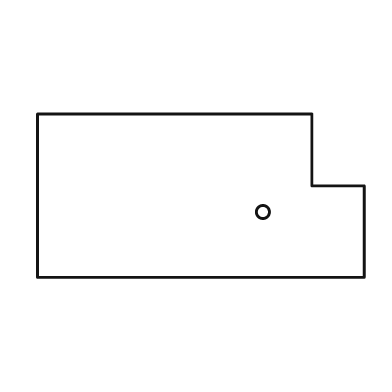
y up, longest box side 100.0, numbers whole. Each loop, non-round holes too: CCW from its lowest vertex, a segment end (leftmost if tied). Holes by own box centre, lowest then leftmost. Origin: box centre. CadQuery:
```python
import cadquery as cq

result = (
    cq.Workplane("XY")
    .moveTo(-50.0, -25.0)
    .lineTo(50.0, -25.0)
    .lineTo(50.0, 3.0)
    .lineTo(34.0, 3.0)
    .lineTo(34.0, 25.0)
    .lineTo(-50.0, 25.0)
    .close()
    .moveTo(19.0, -5.0)
    .circle(2.0)
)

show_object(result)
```